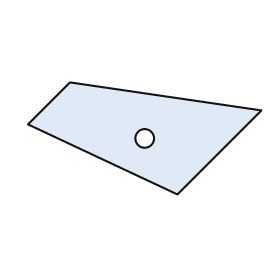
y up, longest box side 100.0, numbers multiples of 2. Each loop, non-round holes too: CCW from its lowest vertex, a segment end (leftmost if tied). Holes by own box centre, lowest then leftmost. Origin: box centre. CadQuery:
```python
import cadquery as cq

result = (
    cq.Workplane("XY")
    .moveTo(14.0, -24.0)
    .lineTo(50.0, 12.0)
    .lineTo(-32.0, 24.0)
    .lineTo(-50.0, 6.0)
    .close()
    .moveTo(0.0, 0.0)
    .circle(4.0)
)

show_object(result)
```